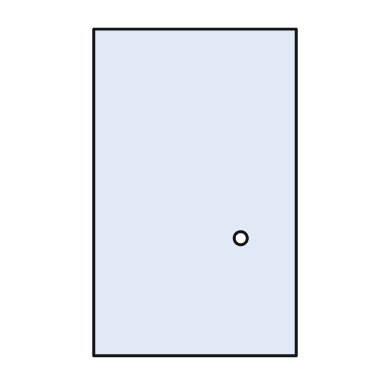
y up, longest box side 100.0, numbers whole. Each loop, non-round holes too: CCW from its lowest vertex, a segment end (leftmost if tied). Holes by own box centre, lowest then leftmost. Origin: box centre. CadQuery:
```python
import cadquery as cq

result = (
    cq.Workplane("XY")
    .moveTo(-31.0, -50.0)
    .lineTo(31.0, -50.0)
    .lineTo(31.0, 50.0)
    .lineTo(-31.0, 50.0)
    .close()
    .moveTo(14.0, -14.0)
    .circle(2.0)
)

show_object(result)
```